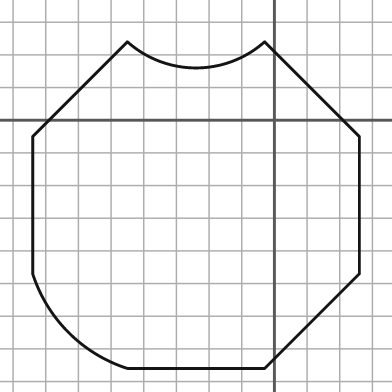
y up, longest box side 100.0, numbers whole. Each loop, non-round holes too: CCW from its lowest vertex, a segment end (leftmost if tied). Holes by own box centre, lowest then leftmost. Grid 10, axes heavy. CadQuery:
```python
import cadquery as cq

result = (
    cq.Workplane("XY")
    .moveTo(-45.0, -76.0)
    .lineTo(-3.0, -76.0)
    .lineTo(26.0, -47.0)
    .lineTo(26.0, -5.0)
    .lineTo(-3.0, 24.0)
    .threePointArc((-24.0, 16.0), (-45.0, 24.0))
    .lineTo(-74.0, -5.0)
    .lineTo(-74.0, -47.0)
    .threePointArc((-63.0, -65.0), (-45.0, -76.0))
    .close()
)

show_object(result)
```